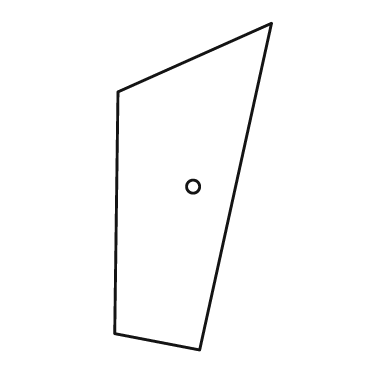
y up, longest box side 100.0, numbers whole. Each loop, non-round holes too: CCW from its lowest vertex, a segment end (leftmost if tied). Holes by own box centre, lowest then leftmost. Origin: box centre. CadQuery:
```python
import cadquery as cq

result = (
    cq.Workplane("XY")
    .moveTo(2.0, -50.0)
    .lineTo(24.0, 50.0)
    .lineTo(-23.0, 29.0)
    .lineTo(-24.0, -45.0)
    .close()
    .moveTo(0.0, 0.0)
    .circle(2.0)
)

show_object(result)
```